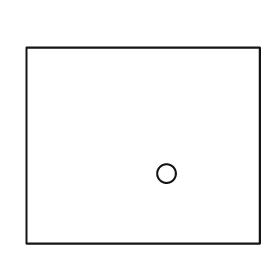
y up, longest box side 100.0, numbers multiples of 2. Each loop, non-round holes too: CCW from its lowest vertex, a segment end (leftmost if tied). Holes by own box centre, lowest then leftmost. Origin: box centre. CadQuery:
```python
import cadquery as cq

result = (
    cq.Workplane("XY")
    .moveTo(-50.0, -42.0)
    .lineTo(50.0, -42.0)
    .lineTo(50.0, 42.0)
    .lineTo(-50.0, 42.0)
    .close()
    .moveTo(10.0, -12.0)
    .circle(4.0)
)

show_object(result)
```